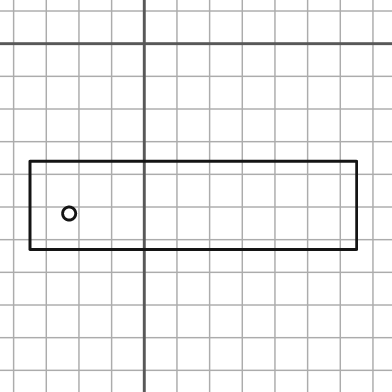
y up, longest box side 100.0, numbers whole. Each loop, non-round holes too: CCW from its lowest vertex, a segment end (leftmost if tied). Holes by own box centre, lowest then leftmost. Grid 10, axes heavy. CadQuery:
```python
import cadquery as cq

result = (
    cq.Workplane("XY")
    .moveTo(-35.0, -63.0)
    .lineTo(65.0, -63.0)
    .lineTo(65.0, -36.0)
    .lineTo(-35.0, -36.0)
    .close()
    .moveTo(-23.0, -52.0)
    .circle(2.0)
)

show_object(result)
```